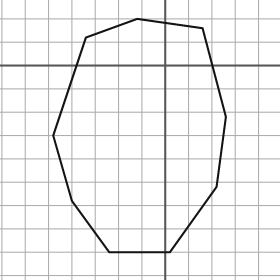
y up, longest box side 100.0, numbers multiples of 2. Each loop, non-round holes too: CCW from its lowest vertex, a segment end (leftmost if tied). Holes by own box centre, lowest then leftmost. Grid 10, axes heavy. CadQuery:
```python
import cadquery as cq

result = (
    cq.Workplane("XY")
    .moveTo(-24.0, -80.0)
    .lineTo(2.0, -80.0)
    .lineTo(22.0, -52.0)
    .lineTo(26.0, -22.0)
    .lineTo(16.0, 16.0)
    .lineTo(-12.0, 20.0)
    .lineTo(-34.0, 12.0)
    .lineTo(-48.0, -30.0)
    .lineTo(-40.0, -58.0)
    .close()
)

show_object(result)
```